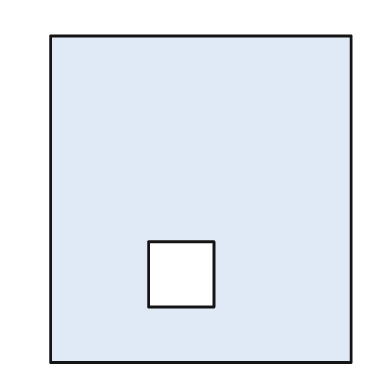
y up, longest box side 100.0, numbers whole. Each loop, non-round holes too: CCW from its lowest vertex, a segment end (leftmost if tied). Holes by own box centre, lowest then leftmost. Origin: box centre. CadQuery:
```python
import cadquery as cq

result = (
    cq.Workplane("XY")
    .moveTo(-46.0, -50.0)
    .lineTo(46.0, -50.0)
    .lineTo(46.0, 50.0)
    .lineTo(-46.0, 50.0)
    .close()
    .moveTo(-16.0, -33.0)
    .lineTo(4.0, -33.0)
    .lineTo(4.0, -13.0)
    .lineTo(-16.0, -13.0)
    .close()
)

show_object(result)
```